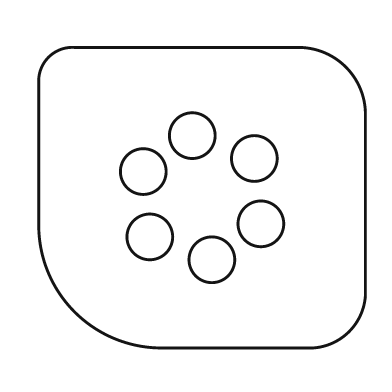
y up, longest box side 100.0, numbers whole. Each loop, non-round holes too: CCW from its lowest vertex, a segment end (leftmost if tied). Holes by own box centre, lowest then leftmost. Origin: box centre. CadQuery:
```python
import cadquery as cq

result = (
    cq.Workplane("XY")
    .moveTo(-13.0, -46.0)
    .lineTo(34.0, -46.0)
    .threePointArc((45.0, -41.0), (50.0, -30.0))
    .lineTo(50.0, 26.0)
    .threePointArc((44.0, 40.0), (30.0, 46.0))
    .lineTo(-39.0, 46.0)
    .threePointArc((-47.0, 43.0), (-50.0, 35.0))
    .lineTo(-50.0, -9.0)
    .threePointArc((-39.0, -35.0), (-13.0, -46.0))
    .close()
    .moveTo(3.0, -19.0)
    .circle(7.0)
    .moveTo(-16.0, -12.0)
    .circle(7.0)
    .moveTo(18.0, -8.0)
    .circle(7.0)
    .moveTo(-18.0, 8.0)
    .circle(7.0)
    .moveTo(16.0, 12.0)
    .circle(7.0)
    .moveTo(-3.0, 19.0)
    .circle(7.0)
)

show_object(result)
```